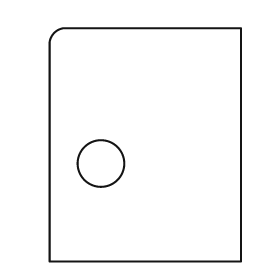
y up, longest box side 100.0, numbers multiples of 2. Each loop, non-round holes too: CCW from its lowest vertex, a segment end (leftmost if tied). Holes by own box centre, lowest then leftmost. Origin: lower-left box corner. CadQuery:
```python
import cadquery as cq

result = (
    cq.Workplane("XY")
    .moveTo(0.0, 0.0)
    .lineTo(82.0, 0.0)
    .lineTo(82.0, 100.0)
    .lineTo(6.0, 100.0)
    .threePointArc((2.0, 98.0), (0.0, 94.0))
    .close()
    .moveTo(22.0, 42.0)
    .circle(10.0)
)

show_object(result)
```